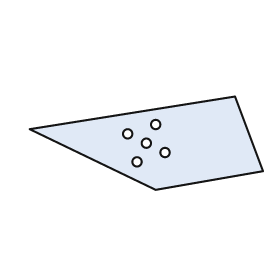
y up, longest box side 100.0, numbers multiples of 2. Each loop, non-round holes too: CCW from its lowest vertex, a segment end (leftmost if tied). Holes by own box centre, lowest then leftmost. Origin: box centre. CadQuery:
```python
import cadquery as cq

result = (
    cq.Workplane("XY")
    .moveTo(4.0, -20.0)
    .lineTo(50.0, -12.0)
    .lineTo(38.0, 20.0)
    .lineTo(-50.0, 6.0)
    .close()
    .moveTo(-4.0, -8.0)
    .circle(2.0)
    .moveTo(8.0, -4.0)
    .circle(2.0)
    .moveTo(0.0, 0.0)
    .circle(2.0)
    .moveTo(-8.0, 4.0)
    .circle(2.0)
    .moveTo(4.0, 8.0)
    .circle(2.0)
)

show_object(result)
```